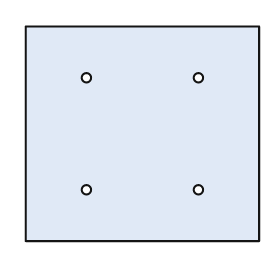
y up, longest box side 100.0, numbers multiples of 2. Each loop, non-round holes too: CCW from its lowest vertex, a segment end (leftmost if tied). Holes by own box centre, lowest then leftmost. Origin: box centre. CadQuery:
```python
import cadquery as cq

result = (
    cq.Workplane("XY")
    .moveTo(-50.0, -46.0)
    .lineTo(50.0, -46.0)
    .lineTo(50.0, 46.0)
    .lineTo(-50.0, 46.0)
    .close()
    .moveTo(-24.0, -24.0)
    .circle(2.0)
    .moveTo(24.0, -24.0)
    .circle(2.0)
    .moveTo(-24.0, 24.0)
    .circle(2.0)
    .moveTo(24.0, 24.0)
    .circle(2.0)
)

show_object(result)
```